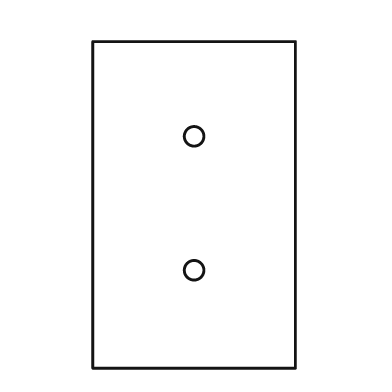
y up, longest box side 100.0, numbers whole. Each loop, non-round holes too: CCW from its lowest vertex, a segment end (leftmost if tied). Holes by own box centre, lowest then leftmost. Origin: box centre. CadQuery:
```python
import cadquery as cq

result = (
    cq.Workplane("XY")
    .moveTo(-31.0, -50.0)
    .lineTo(31.0, -50.0)
    .lineTo(31.0, 50.0)
    .lineTo(-31.0, 50.0)
    .close()
    .moveTo(0.0, -20.0)
    .circle(3.0)
    .moveTo(0.0, 21.0)
    .circle(3.0)
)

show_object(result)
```